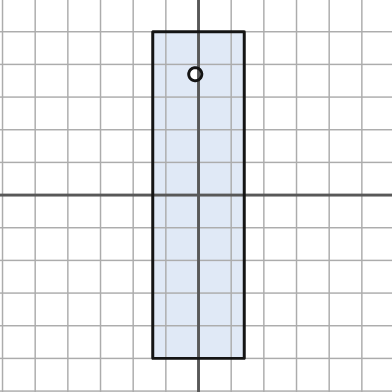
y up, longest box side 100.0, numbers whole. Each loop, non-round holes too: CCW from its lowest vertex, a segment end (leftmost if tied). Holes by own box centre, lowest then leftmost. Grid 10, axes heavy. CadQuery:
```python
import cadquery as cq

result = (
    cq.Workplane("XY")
    .moveTo(-14.0, -50.0)
    .lineTo(14.0, -50.0)
    .lineTo(14.0, 50.0)
    .lineTo(-14.0, 50.0)
    .close()
    .moveTo(-1.0, 37.0)
    .circle(2.0)
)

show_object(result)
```